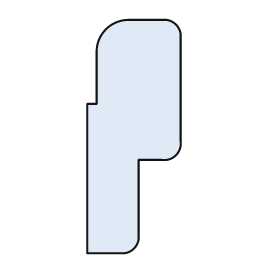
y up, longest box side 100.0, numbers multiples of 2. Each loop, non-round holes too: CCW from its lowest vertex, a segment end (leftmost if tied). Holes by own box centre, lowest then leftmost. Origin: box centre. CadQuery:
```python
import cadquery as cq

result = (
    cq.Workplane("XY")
    .moveTo(-20.0, -50.0)
    .lineTo(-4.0, -50.0)
    .threePointArc((0.0, -48.0), (2.0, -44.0))
    .lineTo(2.0, -10.0)
    .lineTo(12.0, -10.0)
    .threePointArc((18.0, -8.0), (20.0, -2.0))
    .lineTo(20.0, 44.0)
    .threePointArc((18.0, 48.0), (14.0, 50.0))
    .lineTo(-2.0, 50.0)
    .threePointArc((-12.0, 46.0), (-16.0, 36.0))
    .lineTo(-16.0, 14.0)
    .lineTo(-20.0, 14.0)
    .close()
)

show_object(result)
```